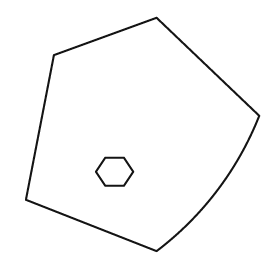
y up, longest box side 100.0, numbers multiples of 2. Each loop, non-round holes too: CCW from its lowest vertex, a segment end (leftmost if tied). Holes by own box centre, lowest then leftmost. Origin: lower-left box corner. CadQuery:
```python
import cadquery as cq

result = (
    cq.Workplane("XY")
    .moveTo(56.0, 0.0)
    .threePointArc((82.0, 26.0), (100.0, 58.0))
    .lineTo(56.0, 100.0)
    .lineTo(12.0, 84.0)
    .lineTo(0.0, 22.0)
    .close()
    .moveTo(34.0, 28.0)
    .lineTo(42.0, 28.0)
    .lineTo(46.0, 34.0)
    .lineTo(42.0, 40.0)
    .lineTo(34.0, 40.0)
    .lineTo(30.0, 34.0)
    .close()
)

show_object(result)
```